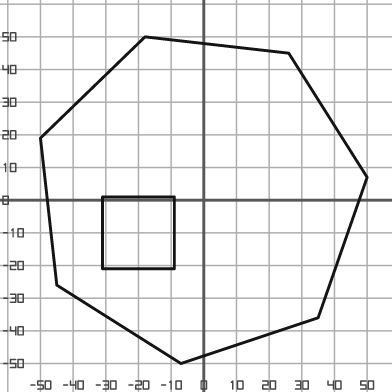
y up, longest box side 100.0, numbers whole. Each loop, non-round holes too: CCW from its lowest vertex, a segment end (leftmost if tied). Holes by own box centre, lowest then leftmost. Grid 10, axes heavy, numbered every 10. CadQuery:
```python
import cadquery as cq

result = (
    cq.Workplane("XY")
    .moveTo(-7.0, -50.0)
    .lineTo(35.0, -36.0)
    .lineTo(50.0, 7.0)
    .lineTo(26.0, 45.0)
    .lineTo(-18.0, 50.0)
    .lineTo(-50.0, 19.0)
    .lineTo(-45.0, -26.0)
    .close()
    .moveTo(-31.0, -21.0)
    .lineTo(-9.0, -21.0)
    .lineTo(-9.0, 1.0)
    .lineTo(-31.0, 1.0)
    .close()
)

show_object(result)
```